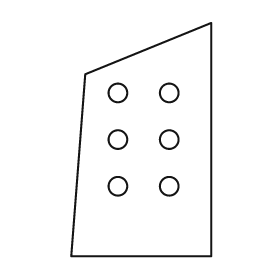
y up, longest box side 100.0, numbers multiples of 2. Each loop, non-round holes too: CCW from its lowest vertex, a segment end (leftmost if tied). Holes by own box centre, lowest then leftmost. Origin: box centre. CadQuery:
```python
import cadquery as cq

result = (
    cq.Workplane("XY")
    .moveTo(-30.0, -50.0)
    .lineTo(30.0, -50.0)
    .lineTo(30.0, 50.0)
    .lineTo(-24.0, 28.0)
    .close()
    .moveTo(-10.0, -20.0)
    .circle(4.0)
    .moveTo(12.0, -20.0)
    .circle(4.0)
    .moveTo(-10.0, 0.0)
    .circle(4.0)
    .moveTo(12.0, 0.0)
    .circle(4.0)
    .moveTo(-10.0, 20.0)
    .circle(4.0)
    .moveTo(12.0, 20.0)
    .circle(4.0)
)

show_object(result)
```